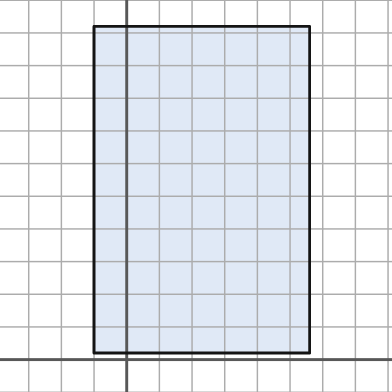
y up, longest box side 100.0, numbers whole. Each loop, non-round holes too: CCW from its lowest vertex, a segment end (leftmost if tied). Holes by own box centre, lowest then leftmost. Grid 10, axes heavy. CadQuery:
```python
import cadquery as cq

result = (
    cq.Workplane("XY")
    .moveTo(-10.0, 2.0)
    .lineTo(56.0, 2.0)
    .lineTo(56.0, 102.0)
    .lineTo(-10.0, 102.0)
    .close()
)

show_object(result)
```